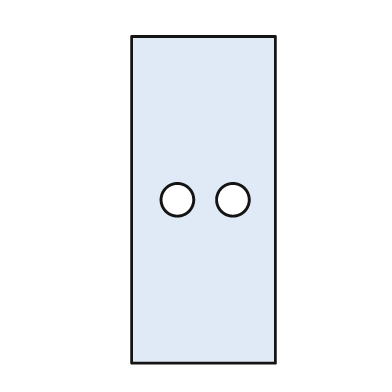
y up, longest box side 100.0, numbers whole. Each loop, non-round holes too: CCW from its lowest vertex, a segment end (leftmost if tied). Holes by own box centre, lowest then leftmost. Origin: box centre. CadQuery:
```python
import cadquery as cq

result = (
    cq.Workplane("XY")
    .moveTo(-22.0, -50.0)
    .lineTo(22.0, -50.0)
    .lineTo(22.0, 50.0)
    .lineTo(-22.0, 50.0)
    .close()
    .moveTo(-8.0, 0.0)
    .circle(5.0)
    .moveTo(9.0, 0.0)
    .circle(5.0)
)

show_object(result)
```